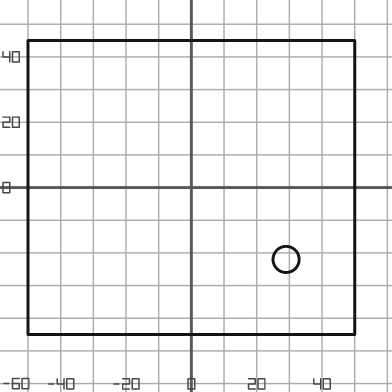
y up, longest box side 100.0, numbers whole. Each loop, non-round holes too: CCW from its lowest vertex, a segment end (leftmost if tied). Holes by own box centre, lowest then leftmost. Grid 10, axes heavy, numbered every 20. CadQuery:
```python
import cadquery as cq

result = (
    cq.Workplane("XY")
    .moveTo(-50.0, -45.0)
    .lineTo(50.0, -45.0)
    .lineTo(50.0, 45.0)
    .lineTo(-50.0, 45.0)
    .close()
    .moveTo(29.0, -22.0)
    .circle(4.0)
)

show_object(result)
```